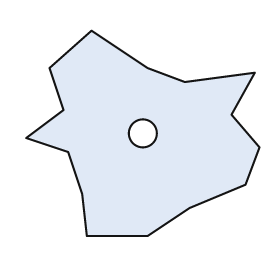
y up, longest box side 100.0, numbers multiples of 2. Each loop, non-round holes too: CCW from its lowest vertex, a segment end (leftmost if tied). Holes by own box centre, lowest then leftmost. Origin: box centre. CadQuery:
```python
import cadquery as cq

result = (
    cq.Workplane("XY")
    .moveTo(-24.0, -44.0)
    .lineTo(2.0, -44.0)
    .lineTo(20.0, -32.0)
    .lineTo(44.0, -22.0)
    .lineTo(50.0, -6.0)
    .lineTo(38.0, 8.0)
    .lineTo(48.0, 26.0)
    .lineTo(18.0, 22.0)
    .lineTo(2.0, 28.0)
    .lineTo(-22.0, 44.0)
    .lineTo(-40.0, 28.0)
    .lineTo(-34.0, 10.0)
    .lineTo(-50.0, -2.0)
    .lineTo(-32.0, -8.0)
    .lineTo(-26.0, -26.0)
    .close()
    .moveTo(0.0, 0.0)
    .circle(6.0)
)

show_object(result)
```